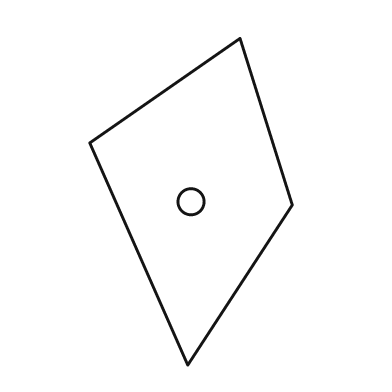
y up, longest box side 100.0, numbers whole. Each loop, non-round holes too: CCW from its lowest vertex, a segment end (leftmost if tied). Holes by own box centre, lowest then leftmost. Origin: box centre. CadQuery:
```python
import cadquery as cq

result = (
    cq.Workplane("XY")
    .moveTo(-1.0, -50.0)
    .lineTo(31.0, -1.0)
    .lineTo(15.0, 50.0)
    .lineTo(-31.0, 18.0)
    .close()
    .moveTo(0.0, 0.0)
    .circle(4.0)
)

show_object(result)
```